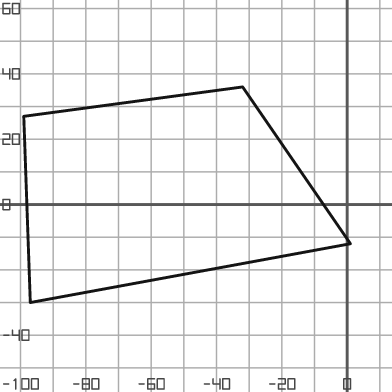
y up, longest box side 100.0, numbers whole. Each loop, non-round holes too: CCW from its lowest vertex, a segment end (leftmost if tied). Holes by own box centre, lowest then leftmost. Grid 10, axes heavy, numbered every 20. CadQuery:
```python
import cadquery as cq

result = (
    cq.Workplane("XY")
    .moveTo(-97.0, -30.0)
    .lineTo(1.0, -12.0)
    .lineTo(-32.0, 36.0)
    .lineTo(-99.0, 27.0)
    .close()
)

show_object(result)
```